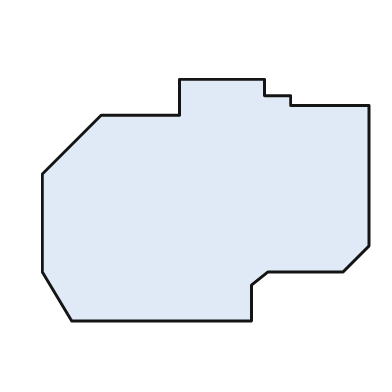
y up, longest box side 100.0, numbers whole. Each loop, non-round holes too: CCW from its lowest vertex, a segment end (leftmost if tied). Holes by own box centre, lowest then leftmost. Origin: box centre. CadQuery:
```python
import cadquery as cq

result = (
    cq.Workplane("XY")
    .moveTo(-41.0, -37.0)
    .lineTo(14.0, -37.0)
    .lineTo(14.0, -26.0)
    .lineTo(19.0, -22.0)
    .lineTo(42.0, -22.0)
    .lineTo(50.0, -14.0)
    .lineTo(50.0, 29.0)
    .lineTo(26.0, 29.0)
    .lineTo(26.0, 32.0)
    .lineTo(18.0, 32.0)
    .lineTo(18.0, 37.0)
    .lineTo(-8.0, 37.0)
    .lineTo(-8.0, 26.0)
    .lineTo(-32.0, 26.0)
    .lineTo(-50.0, 8.0)
    .lineTo(-50.0, -22.0)
    .close()
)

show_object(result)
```